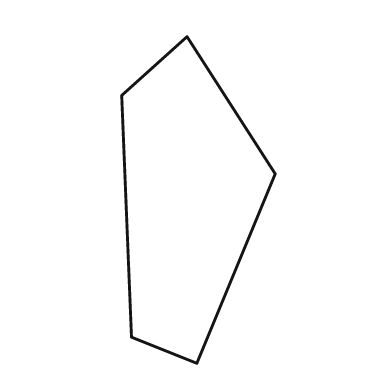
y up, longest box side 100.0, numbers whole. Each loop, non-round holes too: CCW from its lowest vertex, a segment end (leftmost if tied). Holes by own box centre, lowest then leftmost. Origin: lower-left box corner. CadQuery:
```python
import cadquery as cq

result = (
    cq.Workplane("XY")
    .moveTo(23.0, 0.0)
    .lineTo(47.0, 58.0)
    .lineTo(20.0, 100.0)
    .lineTo(0.0, 82.0)
    .lineTo(3.0, 8.0)
    .close()
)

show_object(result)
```